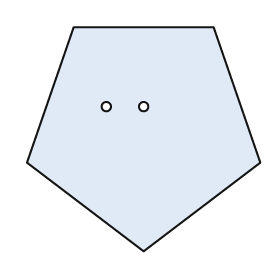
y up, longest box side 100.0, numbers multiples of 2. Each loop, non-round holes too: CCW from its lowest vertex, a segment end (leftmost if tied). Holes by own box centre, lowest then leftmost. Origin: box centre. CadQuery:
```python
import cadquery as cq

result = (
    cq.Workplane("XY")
    .moveTo(0.0, -48.0)
    .lineTo(50.0, -10.0)
    .lineTo(30.0, 48.0)
    .lineTo(-30.0, 48.0)
    .lineTo(-50.0, -10.0)
    .close()
    .moveTo(-16.0, 14.0)
    .circle(2.0)
    .moveTo(0.0, 14.0)
    .circle(2.0)
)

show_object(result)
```